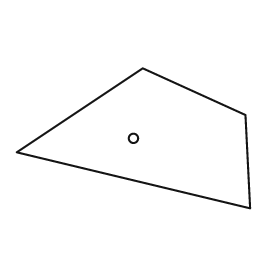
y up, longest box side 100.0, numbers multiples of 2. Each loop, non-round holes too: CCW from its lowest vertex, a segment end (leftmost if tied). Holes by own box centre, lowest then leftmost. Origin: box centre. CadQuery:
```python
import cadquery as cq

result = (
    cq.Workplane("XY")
    .moveTo(50.0, -30.0)
    .lineTo(48.0, 10.0)
    .lineTo(4.0, 30.0)
    .lineTo(-50.0, -6.0)
    .close()
    .moveTo(0.0, 0.0)
    .circle(2.0)
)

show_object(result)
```